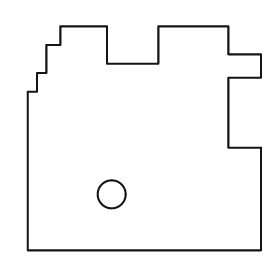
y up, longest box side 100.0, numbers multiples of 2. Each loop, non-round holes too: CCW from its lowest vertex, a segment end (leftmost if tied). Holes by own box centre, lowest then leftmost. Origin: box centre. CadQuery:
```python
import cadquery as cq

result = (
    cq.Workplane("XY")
    .moveTo(-50.0, -48.0)
    .lineTo(50.0, -48.0)
    .lineTo(50.0, -4.0)
    .lineTo(36.0, -4.0)
    .lineTo(36.0, 26.0)
    .lineTo(50.0, 26.0)
    .lineTo(50.0, 36.0)
    .lineTo(36.0, 36.0)
    .lineTo(36.0, 48.0)
    .lineTo(6.0, 48.0)
    .lineTo(6.0, 32.0)
    .lineTo(-16.0, 32.0)
    .lineTo(-16.0, 48.0)
    .lineTo(-36.0, 48.0)
    .lineTo(-36.0, 40.0)
    .lineTo(-42.0, 40.0)
    .lineTo(-42.0, 28.0)
    .lineTo(-46.0, 28.0)
    .lineTo(-46.0, 20.0)
    .lineTo(-50.0, 20.0)
    .close()
    .moveTo(-14.0, -24.0)
    .circle(6.0)
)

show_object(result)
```